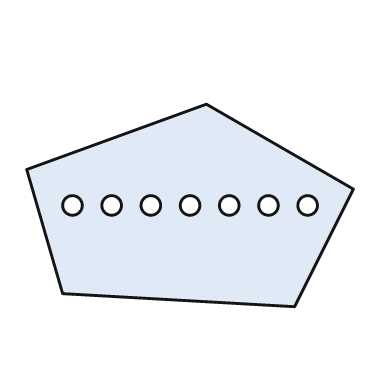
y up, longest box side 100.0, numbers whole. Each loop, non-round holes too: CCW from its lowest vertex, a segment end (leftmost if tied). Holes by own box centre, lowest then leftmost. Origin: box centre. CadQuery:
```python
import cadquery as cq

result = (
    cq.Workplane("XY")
    .moveTo(32.0, -31.0)
    .lineTo(50.0, 5.0)
    .lineTo(5.0, 31.0)
    .lineTo(-50.0, 11.0)
    .lineTo(-39.0, -27.0)
    .close()
    .moveTo(-36.0, 0.0)
    .circle(3.0)
    .moveTo(-24.0, 0.0)
    .circle(3.0)
    .moveTo(-12.0, 0.0)
    .circle(3.0)
    .moveTo(0.0, 0.0)
    .circle(3.0)
    .moveTo(12.0, 0.0)
    .circle(3.0)
    .moveTo(24.0, 0.0)
    .circle(3.0)
    .moveTo(36.0, 0.0)
    .circle(3.0)
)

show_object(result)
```